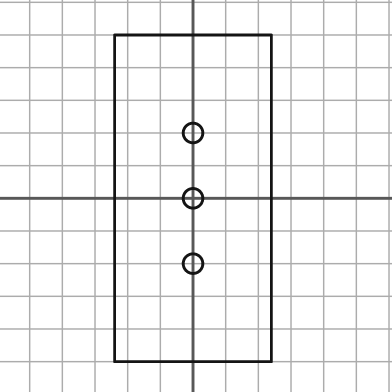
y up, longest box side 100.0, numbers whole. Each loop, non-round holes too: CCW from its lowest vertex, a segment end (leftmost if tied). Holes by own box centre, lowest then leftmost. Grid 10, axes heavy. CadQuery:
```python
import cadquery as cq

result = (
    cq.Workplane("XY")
    .moveTo(-24.0, -50.0)
    .lineTo(24.0, -50.0)
    .lineTo(24.0, 50.0)
    .lineTo(-24.0, 50.0)
    .close()
    .moveTo(0.0, -20.0)
    .circle(3.0)
    .moveTo(0.0, 0.0)
    .circle(3.0)
    .moveTo(0.0, 20.0)
    .circle(3.0)
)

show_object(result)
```